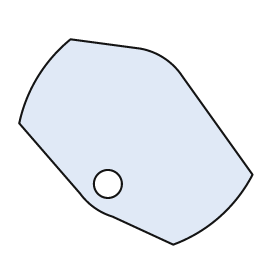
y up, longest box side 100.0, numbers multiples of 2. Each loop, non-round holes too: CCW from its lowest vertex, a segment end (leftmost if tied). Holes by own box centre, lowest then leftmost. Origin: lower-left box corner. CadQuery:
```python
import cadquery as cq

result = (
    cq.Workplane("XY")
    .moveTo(66.0, 0.0)
    .threePointArc((86.0, 12.0), (100.0, 30.0))
    .lineTo(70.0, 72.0)
    .threePointArc((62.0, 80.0), (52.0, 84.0))
    .lineTo(22.0, 88.0)
    .threePointArc((8.0, 72.0), (0.0, 52.0))
    .lineTo(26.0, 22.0)
    .threePointArc((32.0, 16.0), (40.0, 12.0))
    .close()
    .moveTo(38.0, 26.0)
    .circle(6.0)
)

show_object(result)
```